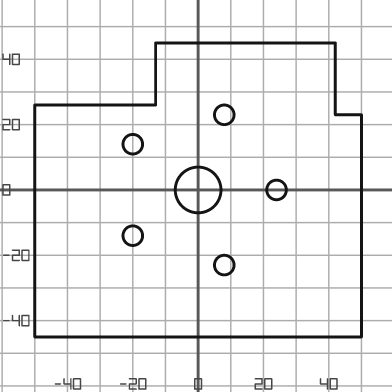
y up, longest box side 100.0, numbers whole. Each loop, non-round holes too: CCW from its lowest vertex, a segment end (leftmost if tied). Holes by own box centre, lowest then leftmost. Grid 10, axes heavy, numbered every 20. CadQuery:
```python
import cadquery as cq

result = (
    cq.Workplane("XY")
    .moveTo(-50.0, -45.0)
    .lineTo(50.0, -45.0)
    .lineTo(50.0, 23.0)
    .lineTo(42.0, 23.0)
    .lineTo(42.0, 45.0)
    .lineTo(-13.0, 45.0)
    .lineTo(-13.0, 26.0)
    .lineTo(-50.0, 26.0)
    .close()
    .moveTo(8.0, -23.0)
    .circle(3.0)
    .moveTo(-20.0, -14.0)
    .circle(3.0)
    .moveTo(0.0, 0.0)
    .circle(7.0)
    .moveTo(24.0, 0.0)
    .circle(3.0)
    .moveTo(-20.0, 14.0)
    .circle(3.0)
    .moveTo(8.0, 23.0)
    .circle(3.0)
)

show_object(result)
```